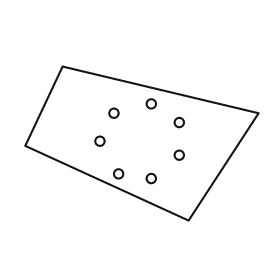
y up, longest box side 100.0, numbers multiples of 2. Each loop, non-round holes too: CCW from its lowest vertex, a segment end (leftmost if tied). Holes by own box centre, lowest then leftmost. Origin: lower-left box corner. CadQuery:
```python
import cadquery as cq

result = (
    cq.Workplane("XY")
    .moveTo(70.0, 0.0)
    .lineTo(100.0, 46.0)
    .lineTo(16.0, 66.0)
    .lineTo(0.0, 32.0)
    .close()
    .moveTo(54.0, 18.0)
    .circle(2.0)
    .moveTo(40.0, 20.0)
    .circle(2.0)
    .moveTo(66.0, 28.0)
    .circle(2.0)
    .moveTo(32.0, 34.0)
    .circle(2.0)
    .moveTo(66.0, 42.0)
    .circle(2.0)
    .moveTo(38.0, 46.0)
    .circle(2.0)
    .moveTo(54.0, 50.0)
    .circle(2.0)
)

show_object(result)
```